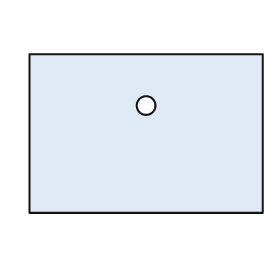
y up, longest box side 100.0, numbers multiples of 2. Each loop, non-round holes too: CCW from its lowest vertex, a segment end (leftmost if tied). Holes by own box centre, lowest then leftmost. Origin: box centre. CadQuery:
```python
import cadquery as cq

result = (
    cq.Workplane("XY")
    .moveTo(-50.0, -34.0)
    .lineTo(50.0, -34.0)
    .lineTo(50.0, 34.0)
    .lineTo(-50.0, 34.0)
    .close()
    .moveTo(0.0, 12.0)
    .circle(4.0)
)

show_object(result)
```